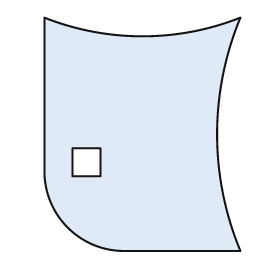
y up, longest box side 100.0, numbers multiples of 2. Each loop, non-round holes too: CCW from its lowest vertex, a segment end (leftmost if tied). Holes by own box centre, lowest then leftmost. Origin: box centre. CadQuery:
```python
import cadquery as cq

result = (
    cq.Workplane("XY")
    .moveTo(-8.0, -50.0)
    .lineTo(42.0, -50.0)
    .threePointArc((32.0, 0.0), (42.0, 50.0))
    .threePointArc((0.0, 42.0), (-42.0, 50.0))
    .lineTo(-42.0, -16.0)
    .threePointArc((-32.0, -40.0), (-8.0, -50.0))
    .close()
    .moveTo(-30.0, -18.0)
    .lineTo(-18.0, -18.0)
    .lineTo(-18.0, -6.0)
    .lineTo(-30.0, -6.0)
    .close()
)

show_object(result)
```